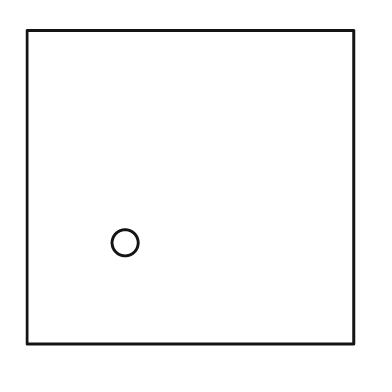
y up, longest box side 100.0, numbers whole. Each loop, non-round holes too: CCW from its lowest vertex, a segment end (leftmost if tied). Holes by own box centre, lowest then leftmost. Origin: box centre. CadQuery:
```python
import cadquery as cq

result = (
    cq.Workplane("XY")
    .moveTo(-50.0, -48.0)
    .lineTo(50.0, -48.0)
    .lineTo(50.0, 48.0)
    .lineTo(-50.0, 48.0)
    .close()
    .moveTo(-20.0, -17.0)
    .circle(4.0)
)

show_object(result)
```